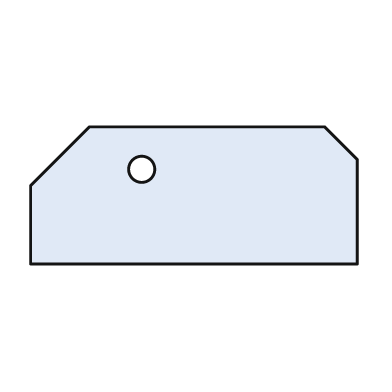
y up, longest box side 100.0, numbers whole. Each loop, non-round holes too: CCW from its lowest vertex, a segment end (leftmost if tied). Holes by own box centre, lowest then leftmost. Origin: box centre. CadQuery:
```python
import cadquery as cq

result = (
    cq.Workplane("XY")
    .moveTo(-50.0, -21.0)
    .lineTo(50.0, -21.0)
    .lineTo(50.0, 11.0)
    .lineTo(40.0, 21.0)
    .lineTo(-32.0, 21.0)
    .lineTo(-50.0, 3.0)
    .close()
    .moveTo(-16.0, 8.0)
    .circle(4.0)
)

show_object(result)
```